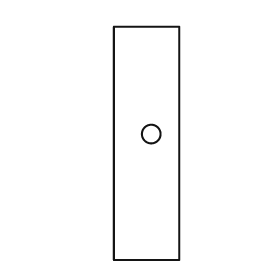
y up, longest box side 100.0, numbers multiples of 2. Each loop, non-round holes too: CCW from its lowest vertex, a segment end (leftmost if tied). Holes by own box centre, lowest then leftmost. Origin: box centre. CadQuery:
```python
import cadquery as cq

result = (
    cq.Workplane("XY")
    .moveTo(-14.0, -50.0)
    .lineTo(14.0, -50.0)
    .lineTo(14.0, 50.0)
    .lineTo(-14.0, 50.0)
    .close()
    .moveTo(2.0, 4.0)
    .circle(4.0)
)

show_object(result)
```